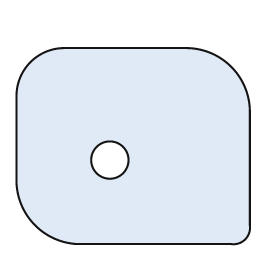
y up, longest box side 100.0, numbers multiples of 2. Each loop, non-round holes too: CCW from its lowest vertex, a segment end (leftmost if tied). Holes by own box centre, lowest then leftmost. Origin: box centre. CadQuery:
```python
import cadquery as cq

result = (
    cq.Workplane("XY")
    .moveTo(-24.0, -42.0)
    .lineTo(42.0, -42.0)
    .threePointArc((48.0, -40.0), (50.0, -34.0))
    .lineTo(50.0, 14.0)
    .threePointArc((42.0, 34.0), (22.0, 42.0))
    .lineTo(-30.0, 42.0)
    .threePointArc((-44.0, 36.0), (-50.0, 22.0))
    .lineTo(-50.0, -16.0)
    .threePointArc((-42.0, -34.0), (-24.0, -42.0))
    .close()
    .moveTo(-10.0, -6.0)
    .circle(8.0)
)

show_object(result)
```